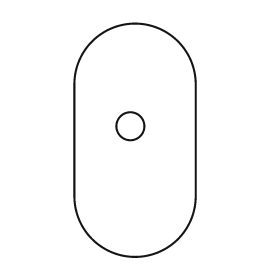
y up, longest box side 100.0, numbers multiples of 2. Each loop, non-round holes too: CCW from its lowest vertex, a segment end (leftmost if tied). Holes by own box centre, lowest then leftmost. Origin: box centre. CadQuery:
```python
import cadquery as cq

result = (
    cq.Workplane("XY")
    .moveTo(-26.0, -24.0)
    .threePointArc((0.0, -50.0), (26.0, -24.0))
    .lineTo(26.0, 24.0)
    .threePointArc((0.0, 50.0), (-26.0, 24.0))
    .close()
    .moveTo(-2.0, 6.0)
    .circle(6.0)
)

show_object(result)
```